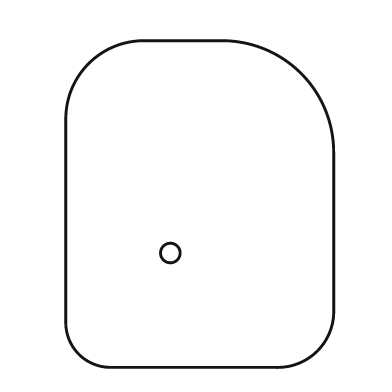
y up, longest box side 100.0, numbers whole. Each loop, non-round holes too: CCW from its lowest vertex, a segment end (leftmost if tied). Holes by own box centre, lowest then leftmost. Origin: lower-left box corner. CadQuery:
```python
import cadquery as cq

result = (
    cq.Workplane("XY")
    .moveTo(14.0, 0.0)
    .lineTo(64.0, 0.0)
    .threePointArc((77.0, 5.0), (82.0, 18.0))
    .lineTo(82.0, 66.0)
    .threePointArc((72.0, 90.0), (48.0, 100.0))
    .lineTo(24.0, 100.0)
    .threePointArc((7.0, 93.0), (0.0, 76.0))
    .lineTo(0.0, 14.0)
    .threePointArc((4.0, 4.0), (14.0, 0.0))
    .close()
    .moveTo(32.0, 35.0)
    .circle(3.0)
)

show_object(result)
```